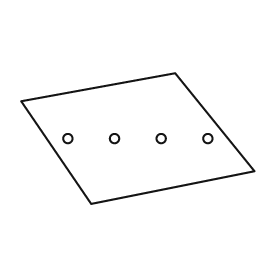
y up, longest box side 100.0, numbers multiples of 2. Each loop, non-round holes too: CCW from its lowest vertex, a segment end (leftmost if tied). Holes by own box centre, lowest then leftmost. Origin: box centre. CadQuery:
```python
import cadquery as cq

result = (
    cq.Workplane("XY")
    .moveTo(-20.0, -28.0)
    .lineTo(50.0, -14.0)
    .lineTo(16.0, 28.0)
    .lineTo(-50.0, 16.0)
    .close()
    .moveTo(-30.0, 0.0)
    .circle(2.0)
    .moveTo(-10.0, 0.0)
    .circle(2.0)
    .moveTo(10.0, 0.0)
    .circle(2.0)
    .moveTo(30.0, 0.0)
    .circle(2.0)
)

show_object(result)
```